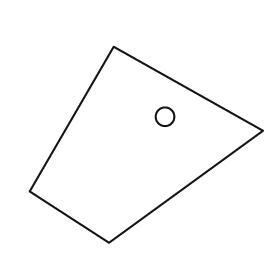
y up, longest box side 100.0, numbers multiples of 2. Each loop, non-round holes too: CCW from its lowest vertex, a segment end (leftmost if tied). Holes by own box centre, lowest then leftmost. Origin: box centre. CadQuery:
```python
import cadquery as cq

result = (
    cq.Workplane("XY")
    .moveTo(-16.0, -42.0)
    .lineTo(50.0, 6.0)
    .lineTo(-14.0, 42.0)
    .lineTo(-50.0, -20.0)
    .close()
    .moveTo(8.0, 12.0)
    .circle(4.0)
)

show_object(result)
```